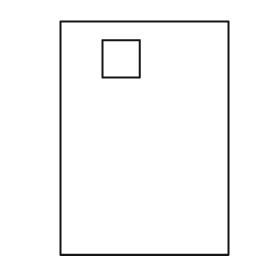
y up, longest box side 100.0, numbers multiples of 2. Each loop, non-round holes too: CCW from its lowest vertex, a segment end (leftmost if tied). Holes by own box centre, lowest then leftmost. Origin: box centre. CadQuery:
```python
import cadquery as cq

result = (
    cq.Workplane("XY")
    .moveTo(-36.0, -50.0)
    .lineTo(36.0, -50.0)
    .lineTo(36.0, 50.0)
    .lineTo(-36.0, 50.0)
    .close()
    .moveTo(-18.0, 26.0)
    .lineTo(-2.0, 26.0)
    .lineTo(-2.0, 42.0)
    .lineTo(-18.0, 42.0)
    .close()
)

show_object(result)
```